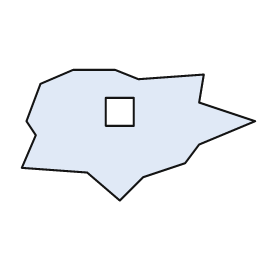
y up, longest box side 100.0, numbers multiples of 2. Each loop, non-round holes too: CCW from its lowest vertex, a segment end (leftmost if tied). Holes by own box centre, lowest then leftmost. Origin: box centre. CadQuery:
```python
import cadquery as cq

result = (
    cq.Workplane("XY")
    .moveTo(-8.0, -28.0)
    .lineTo(2.0, -18.0)
    .lineTo(20.0, -12.0)
    .lineTo(26.0, -4.0)
    .lineTo(50.0, 6.0)
    .lineTo(26.0, 14.0)
    .lineTo(28.0, 26.0)
    .lineTo(0.0, 24.0)
    .lineTo(-10.0, 28.0)
    .lineTo(-28.0, 28.0)
    .lineTo(-42.0, 22.0)
    .lineTo(-48.0, 6.0)
    .lineTo(-44.0, 0.0)
    .lineTo(-50.0, -14.0)
    .lineTo(-22.0, -16.0)
    .close()
    .moveTo(-14.0, 4.0)
    .lineTo(-2.0, 4.0)
    .lineTo(-2.0, 16.0)
    .lineTo(-14.0, 16.0)
    .close()
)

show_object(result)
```